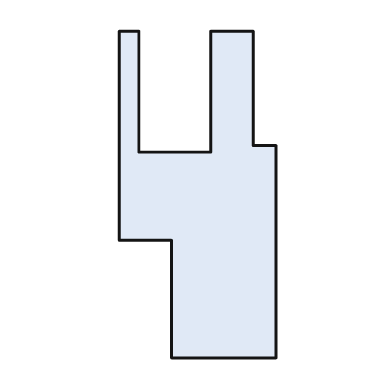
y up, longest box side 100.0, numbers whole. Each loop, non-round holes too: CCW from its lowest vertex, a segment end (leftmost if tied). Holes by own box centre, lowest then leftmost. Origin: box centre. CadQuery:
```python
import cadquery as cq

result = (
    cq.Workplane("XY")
    .moveTo(-8.0, -50.0)
    .lineTo(24.0, -50.0)
    .lineTo(24.0, 15.0)
    .lineTo(17.0, 15.0)
    .lineTo(17.0, 50.0)
    .lineTo(4.0, 50.0)
    .lineTo(4.0, 13.0)
    .lineTo(-18.0, 13.0)
    .lineTo(-18.0, 50.0)
    .lineTo(-24.0, 50.0)
    .lineTo(-24.0, -14.0)
    .lineTo(-8.0, -14.0)
    .close()
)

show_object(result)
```